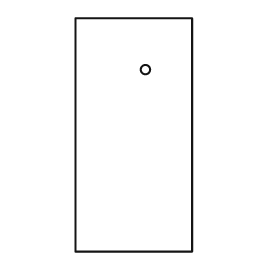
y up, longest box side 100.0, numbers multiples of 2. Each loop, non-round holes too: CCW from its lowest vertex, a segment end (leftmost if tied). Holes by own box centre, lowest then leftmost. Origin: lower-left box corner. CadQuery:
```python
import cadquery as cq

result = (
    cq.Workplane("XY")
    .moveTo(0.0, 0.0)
    .lineTo(50.0, 0.0)
    .lineTo(50.0, 100.0)
    .lineTo(0.0, 100.0)
    .close()
    .moveTo(30.0, 78.0)
    .circle(2.0)
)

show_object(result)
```